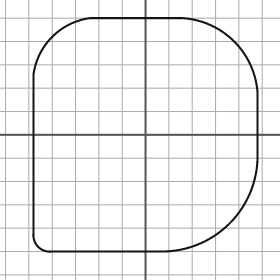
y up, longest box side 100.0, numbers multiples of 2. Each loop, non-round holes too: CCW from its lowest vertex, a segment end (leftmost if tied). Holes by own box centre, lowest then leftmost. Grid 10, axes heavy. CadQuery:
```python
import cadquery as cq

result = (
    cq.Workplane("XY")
    .moveTo(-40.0, -50.0)
    .lineTo(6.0, -50.0)
    .threePointArc((36.0, -38.0), (48.0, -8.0))
    .lineTo(48.0, 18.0)
    .threePointArc((38.0, 40.0), (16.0, 50.0))
    .lineTo(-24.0, 50.0)
    .threePointArc((-40.0, 42.0), (-48.0, 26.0))
    .lineTo(-48.0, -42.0)
    .threePointArc((-46.0, -48.0), (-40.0, -50.0))
    .close()
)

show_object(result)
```